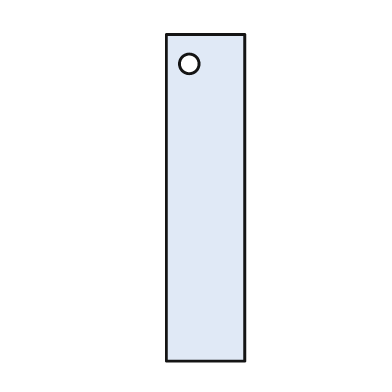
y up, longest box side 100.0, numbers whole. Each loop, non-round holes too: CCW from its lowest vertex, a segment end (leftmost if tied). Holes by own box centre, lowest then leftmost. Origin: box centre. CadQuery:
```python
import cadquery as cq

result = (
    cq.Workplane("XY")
    .moveTo(-12.0, -50.0)
    .lineTo(12.0, -50.0)
    .lineTo(12.0, 50.0)
    .lineTo(-12.0, 50.0)
    .close()
    .moveTo(-5.0, 41.0)
    .circle(3.0)
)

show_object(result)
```